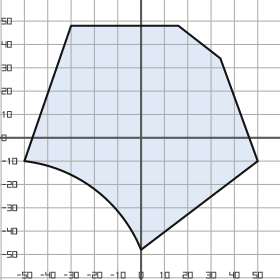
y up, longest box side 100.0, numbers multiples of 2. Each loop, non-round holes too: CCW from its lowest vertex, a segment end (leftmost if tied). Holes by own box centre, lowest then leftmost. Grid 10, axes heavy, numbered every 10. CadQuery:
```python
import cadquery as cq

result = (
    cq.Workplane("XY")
    .moveTo(0.0, -48.0)
    .lineTo(50.0, -10.0)
    .lineTo(34.0, 34.0)
    .lineTo(16.0, 48.0)
    .lineTo(-30.0, 48.0)
    .lineTo(-50.0, -10.0)
    .threePointArc((-20.0, -22.0), (0.0, -48.0))
    .close()
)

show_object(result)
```